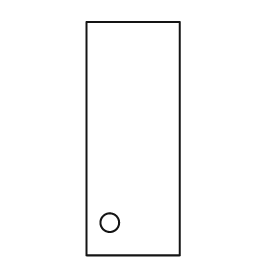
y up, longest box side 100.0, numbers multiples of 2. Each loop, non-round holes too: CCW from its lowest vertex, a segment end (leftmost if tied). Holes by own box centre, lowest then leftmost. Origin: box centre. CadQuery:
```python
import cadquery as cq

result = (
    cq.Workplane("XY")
    .moveTo(-20.0, -50.0)
    .lineTo(20.0, -50.0)
    .lineTo(20.0, 50.0)
    .lineTo(-20.0, 50.0)
    .close()
    .moveTo(-10.0, -36.0)
    .circle(4.0)
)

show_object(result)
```